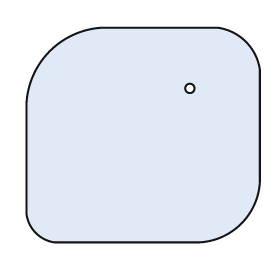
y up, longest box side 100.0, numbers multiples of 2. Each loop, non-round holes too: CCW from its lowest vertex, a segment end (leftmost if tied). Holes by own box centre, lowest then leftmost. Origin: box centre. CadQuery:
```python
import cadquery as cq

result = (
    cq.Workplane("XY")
    .moveTo(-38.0, -46.0)
    .lineTo(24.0, -46.0)
    .threePointArc((42.0, -38.0), (50.0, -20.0))
    .lineTo(50.0, 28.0)
    .threePointArc((44.0, 40.0), (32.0, 46.0))
    .lineTo(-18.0, 46.0)
    .threePointArc((-40.0, 36.0), (-50.0, 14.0))
    .lineTo(-50.0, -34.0)
    .threePointArc((-46.0, -42.0), (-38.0, -46.0))
    .close()
    .moveTo(20.0, 20.0)
    .circle(2.0)
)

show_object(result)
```